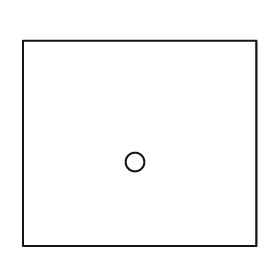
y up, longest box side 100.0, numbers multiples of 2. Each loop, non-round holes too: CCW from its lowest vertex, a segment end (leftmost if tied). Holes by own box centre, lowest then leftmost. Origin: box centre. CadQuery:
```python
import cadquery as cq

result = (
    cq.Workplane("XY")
    .moveTo(-50.0, -44.0)
    .lineTo(50.0, -44.0)
    .lineTo(50.0, 44.0)
    .lineTo(-50.0, 44.0)
    .close()
    .moveTo(-2.0, -8.0)
    .circle(4.0)
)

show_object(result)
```